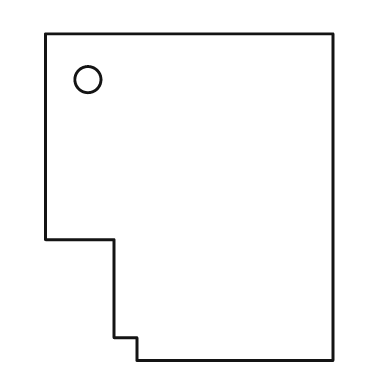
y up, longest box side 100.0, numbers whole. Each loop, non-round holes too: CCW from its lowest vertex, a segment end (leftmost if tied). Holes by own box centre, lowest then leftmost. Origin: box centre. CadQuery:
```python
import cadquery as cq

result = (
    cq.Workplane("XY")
    .moveTo(-16.0, -50.0)
    .lineTo(44.0, -50.0)
    .lineTo(44.0, 50.0)
    .lineTo(-44.0, 50.0)
    .lineTo(-44.0, -13.0)
    .lineTo(-23.0, -13.0)
    .lineTo(-23.0, -43.0)
    .lineTo(-16.0, -43.0)
    .close()
    .moveTo(-31.0, 36.0)
    .circle(4.0)
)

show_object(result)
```